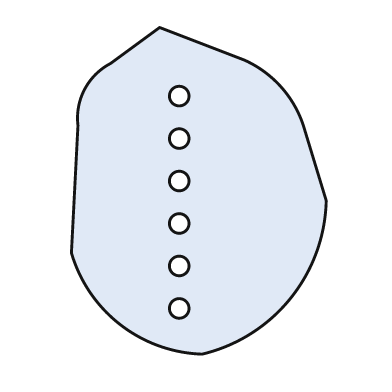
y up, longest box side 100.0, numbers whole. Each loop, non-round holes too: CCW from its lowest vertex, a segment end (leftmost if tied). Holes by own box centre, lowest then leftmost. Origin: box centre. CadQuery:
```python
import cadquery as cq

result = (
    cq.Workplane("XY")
    .moveTo(1.0, -50.0)
    .threePointArc((28.0, -33.0), (39.0, -3.0))
    .lineTo(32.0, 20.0)
    .threePointArc((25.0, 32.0), (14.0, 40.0))
    .lineTo(-12.0, 50.0)
    .lineTo(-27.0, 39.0)
    .threePointArc((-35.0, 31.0), (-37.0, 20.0))
    .lineTo(-39.0, -19.0)
    .threePointArc((-24.0, -41.0), (1.0, -50.0))
    .close()
    .moveTo(-6.0, -36.0)
    .circle(3.0)
    .moveTo(-6.0, -23.0)
    .circle(3.0)
    .moveTo(-6.0, -10.0)
    .circle(3.0)
    .moveTo(-6.0, 3.0)
    .circle(3.0)
    .moveTo(-6.0, 16.0)
    .circle(3.0)
    .moveTo(-6.0, 29.0)
    .circle(3.0)
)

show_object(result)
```